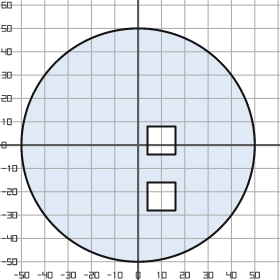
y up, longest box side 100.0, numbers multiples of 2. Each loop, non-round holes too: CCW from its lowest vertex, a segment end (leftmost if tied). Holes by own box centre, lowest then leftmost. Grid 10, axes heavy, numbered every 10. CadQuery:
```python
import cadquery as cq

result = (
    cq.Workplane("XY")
    .moveTo(0.0, 0.0)
    .circle(50.0)
    .moveTo(4.0, -28.0)
    .lineTo(16.0, -28.0)
    .lineTo(16.0, -16.0)
    .lineTo(4.0, -16.0)
    .close()
    .moveTo(4.0, -4.0)
    .lineTo(16.0, -4.0)
    .lineTo(16.0, 8.0)
    .lineTo(4.0, 8.0)
    .close()
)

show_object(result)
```